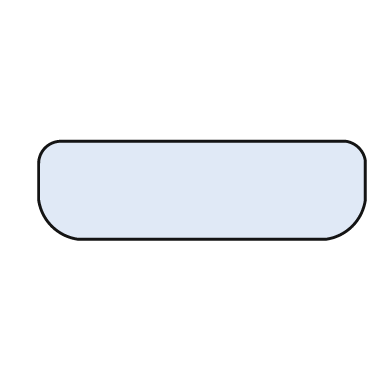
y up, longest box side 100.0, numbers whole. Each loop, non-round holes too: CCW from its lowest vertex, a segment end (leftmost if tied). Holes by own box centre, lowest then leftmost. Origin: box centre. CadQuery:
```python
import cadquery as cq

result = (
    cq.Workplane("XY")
    .moveTo(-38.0, -15.0)
    .lineTo(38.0, -15.0)
    .threePointArc((46.0, -11.0), (50.0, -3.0))
    .lineTo(50.0, 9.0)
    .threePointArc((48.0, 13.0), (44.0, 15.0))
    .lineTo(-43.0, 15.0)
    .threePointArc((-48.0, 13.0), (-50.0, 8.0))
    .lineTo(-50.0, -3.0)
    .threePointArc((-46.0, -11.0), (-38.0, -15.0))
    .close()
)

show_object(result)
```